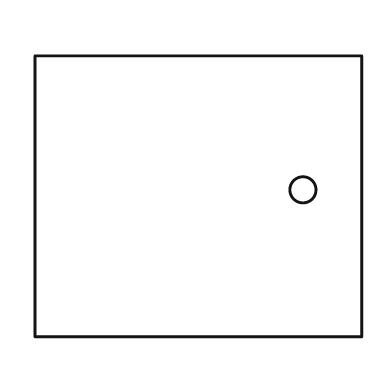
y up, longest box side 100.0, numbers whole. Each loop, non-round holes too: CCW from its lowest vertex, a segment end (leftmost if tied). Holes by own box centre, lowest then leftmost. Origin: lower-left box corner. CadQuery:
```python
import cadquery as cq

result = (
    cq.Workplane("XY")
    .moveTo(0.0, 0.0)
    .lineTo(100.0, 0.0)
    .lineTo(100.0, 86.0)
    .lineTo(0.0, 86.0)
    .close()
    .moveTo(82.0, 45.0)
    .circle(4.0)
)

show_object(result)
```